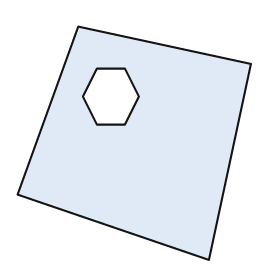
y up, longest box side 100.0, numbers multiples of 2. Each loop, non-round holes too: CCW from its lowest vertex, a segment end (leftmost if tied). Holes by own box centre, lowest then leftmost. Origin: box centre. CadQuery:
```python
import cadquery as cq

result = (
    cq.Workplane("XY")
    .moveTo(32.0, -50.0)
    .lineTo(50.0, 34.0)
    .lineTo(-24.0, 50.0)
    .lineTo(-50.0, -22.0)
    .close()
    .moveTo(-16.0, 8.0)
    .lineTo(-4.0, 8.0)
    .lineTo(2.0, 20.0)
    .lineTo(-4.0, 32.0)
    .lineTo(-16.0, 32.0)
    .lineTo(-22.0, 20.0)
    .close()
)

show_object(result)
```